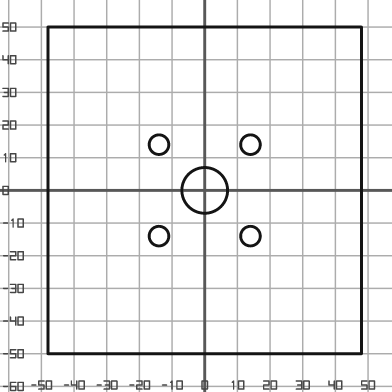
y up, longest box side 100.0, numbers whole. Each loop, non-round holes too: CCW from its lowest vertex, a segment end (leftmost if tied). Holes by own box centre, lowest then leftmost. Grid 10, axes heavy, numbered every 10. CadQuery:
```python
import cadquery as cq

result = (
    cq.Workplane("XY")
    .moveTo(-48.0, -50.0)
    .lineTo(48.0, -50.0)
    .lineTo(48.0, 50.0)
    .lineTo(-48.0, 50.0)
    .close()
    .moveTo(-14.0, -14.0)
    .circle(3.0)
    .moveTo(14.0, -14.0)
    .circle(3.0)
    .moveTo(0.0, 0.0)
    .circle(7.0)
    .moveTo(-14.0, 14.0)
    .circle(3.0)
    .moveTo(14.0, 14.0)
    .circle(3.0)
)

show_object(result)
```